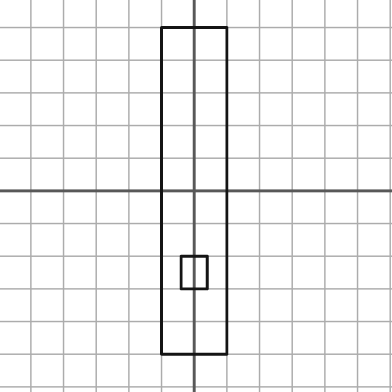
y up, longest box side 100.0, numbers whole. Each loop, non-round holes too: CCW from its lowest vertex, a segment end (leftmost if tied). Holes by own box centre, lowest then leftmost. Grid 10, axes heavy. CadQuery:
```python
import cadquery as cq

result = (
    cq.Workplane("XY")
    .moveTo(-10.0, -50.0)
    .lineTo(10.0, -50.0)
    .lineTo(10.0, 50.0)
    .lineTo(-10.0, 50.0)
    .close()
    .moveTo(-4.0, -30.0)
    .lineTo(4.0, -30.0)
    .lineTo(4.0, -20.0)
    .lineTo(-4.0, -20.0)
    .close()
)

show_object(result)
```